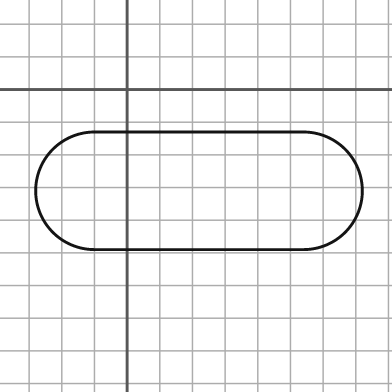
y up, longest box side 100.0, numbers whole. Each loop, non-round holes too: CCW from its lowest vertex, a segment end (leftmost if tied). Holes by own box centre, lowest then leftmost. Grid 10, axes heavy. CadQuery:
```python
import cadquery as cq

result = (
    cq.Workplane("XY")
    .moveTo(-10.0, -49.0)
    .lineTo(54.0, -49.0)
    .threePointArc((72.0, -31.0), (54.0, -13.0))
    .lineTo(-10.0, -13.0)
    .threePointArc((-28.0, -31.0), (-10.0, -49.0))
    .close()
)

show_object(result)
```